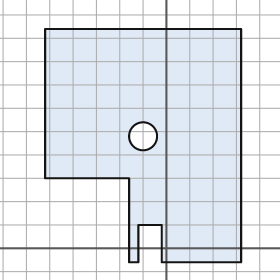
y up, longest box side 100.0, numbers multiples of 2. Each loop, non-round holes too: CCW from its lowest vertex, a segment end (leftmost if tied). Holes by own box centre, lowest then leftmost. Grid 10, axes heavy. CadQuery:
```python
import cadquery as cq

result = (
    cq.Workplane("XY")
    .moveTo(-16.0, -6.0)
    .lineTo(-12.0, -6.0)
    .lineTo(-12.0, 10.0)
    .lineTo(-2.0, 10.0)
    .lineTo(-2.0, -6.0)
    .lineTo(32.0, -6.0)
    .lineTo(32.0, 94.0)
    .lineTo(-52.0, 94.0)
    .lineTo(-52.0, 30.0)
    .lineTo(-16.0, 30.0)
    .close()
    .moveTo(-10.0, 48.0)
    .circle(6.0)
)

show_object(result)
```